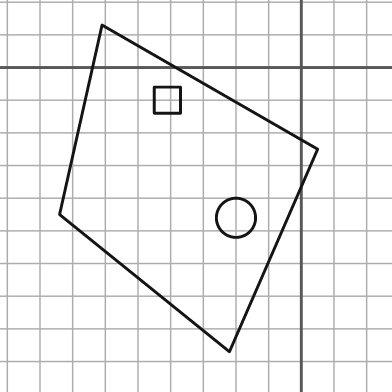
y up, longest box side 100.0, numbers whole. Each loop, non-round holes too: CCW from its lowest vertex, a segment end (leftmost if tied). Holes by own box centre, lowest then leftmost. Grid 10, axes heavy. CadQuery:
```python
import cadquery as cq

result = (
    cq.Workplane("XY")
    .moveTo(-22.0, -87.0)
    .lineTo(5.0, -25.0)
    .lineTo(-61.0, 13.0)
    .lineTo(-74.0, -45.0)
    .close()
    .moveTo(-20.0, -46.0)
    .circle(6.0)
    .moveTo(-45.0, -14.0)
    .lineTo(-37.0, -14.0)
    .lineTo(-37.0, -6.0)
    .lineTo(-45.0, -6.0)
    .close()
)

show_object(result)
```